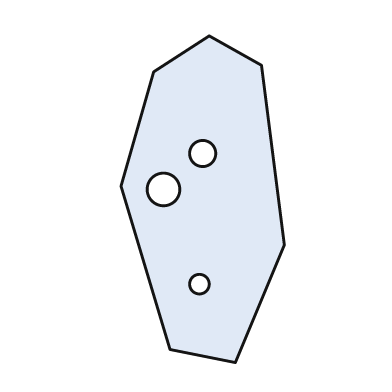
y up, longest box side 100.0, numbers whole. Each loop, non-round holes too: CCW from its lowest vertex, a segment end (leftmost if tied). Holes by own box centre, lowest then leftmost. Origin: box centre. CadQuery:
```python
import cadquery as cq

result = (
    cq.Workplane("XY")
    .moveTo(10.0, -50.0)
    .lineTo(25.0, -14.0)
    .lineTo(18.0, 41.0)
    .lineTo(2.0, 50.0)
    .lineTo(-15.0, 39.0)
    .lineTo(-25.0, 4.0)
    .lineTo(-10.0, -46.0)
    .close()
    .moveTo(-1.0, -26.0)
    .circle(3.0)
    .moveTo(-12.0, 3.0)
    .circle(5.0)
    .moveTo(0.0, 14.0)
    .circle(4.0)
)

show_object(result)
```